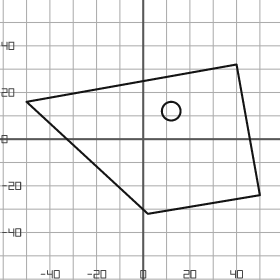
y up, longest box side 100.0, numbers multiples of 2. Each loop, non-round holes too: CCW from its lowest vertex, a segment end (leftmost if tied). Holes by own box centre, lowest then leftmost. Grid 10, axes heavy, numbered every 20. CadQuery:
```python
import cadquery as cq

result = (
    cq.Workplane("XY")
    .moveTo(2.0, -32.0)
    .lineTo(50.0, -24.0)
    .lineTo(40.0, 32.0)
    .lineTo(-50.0, 16.0)
    .close()
    .moveTo(12.0, 12.0)
    .circle(4.0)
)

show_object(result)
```